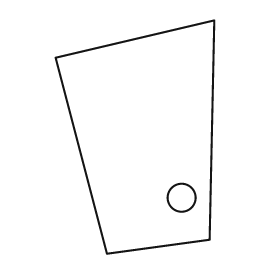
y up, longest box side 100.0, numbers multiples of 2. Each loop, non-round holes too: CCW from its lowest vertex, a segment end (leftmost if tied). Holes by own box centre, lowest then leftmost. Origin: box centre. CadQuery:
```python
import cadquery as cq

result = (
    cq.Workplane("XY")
    .moveTo(-12.0, -50.0)
    .lineTo(32.0, -44.0)
    .lineTo(34.0, 50.0)
    .lineTo(-34.0, 34.0)
    .close()
    .moveTo(20.0, -26.0)
    .circle(6.0)
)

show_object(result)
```